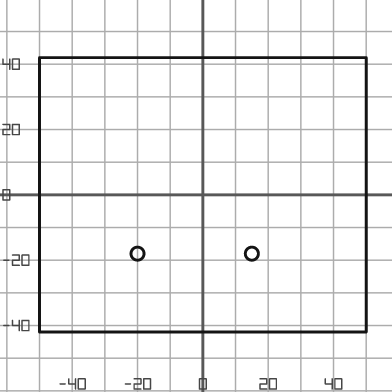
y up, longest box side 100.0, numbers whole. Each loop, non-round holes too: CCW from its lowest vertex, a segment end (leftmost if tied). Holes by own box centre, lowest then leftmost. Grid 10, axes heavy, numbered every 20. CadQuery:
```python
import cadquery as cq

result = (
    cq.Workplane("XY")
    .moveTo(-50.0, -42.0)
    .lineTo(50.0, -42.0)
    .lineTo(50.0, 42.0)
    .lineTo(-50.0, 42.0)
    .close()
    .moveTo(-20.0, -18.0)
    .circle(2.0)
    .moveTo(15.0, -18.0)
    .circle(2.0)
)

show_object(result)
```